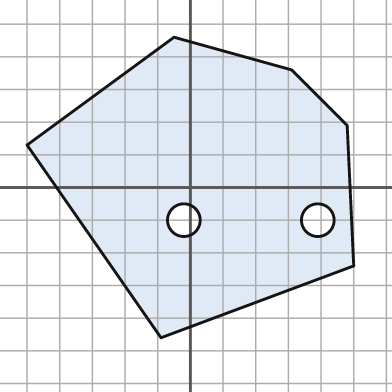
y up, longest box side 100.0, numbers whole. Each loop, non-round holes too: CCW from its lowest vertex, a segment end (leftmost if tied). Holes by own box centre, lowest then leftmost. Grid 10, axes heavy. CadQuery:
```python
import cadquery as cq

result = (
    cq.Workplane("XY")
    .moveTo(-9.0, -46.0)
    .lineTo(50.0, -24.0)
    .lineTo(48.0, 19.0)
    .lineTo(31.0, 36.0)
    .lineTo(-5.0, 46.0)
    .lineTo(-50.0, 13.0)
    .close()
    .moveTo(-2.0, -10.0)
    .circle(5.0)
    .moveTo(39.0, -10.0)
    .circle(5.0)
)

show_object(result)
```